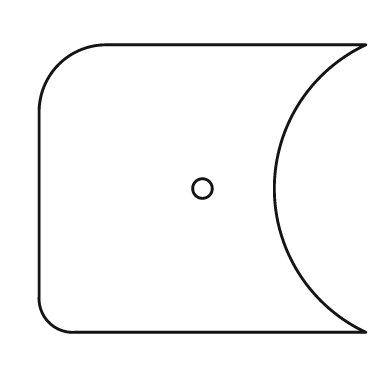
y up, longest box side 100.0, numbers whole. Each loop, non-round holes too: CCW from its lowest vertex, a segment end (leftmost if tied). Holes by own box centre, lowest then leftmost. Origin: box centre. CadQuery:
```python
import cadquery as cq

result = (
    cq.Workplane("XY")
    .moveTo(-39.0, -44.0)
    .lineTo(50.0, -44.0)
    .threePointArc((22.0, 0.0), (50.0, 44.0))
    .lineTo(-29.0, 44.0)
    .threePointArc((-44.0, 38.0), (-50.0, 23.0))
    .lineTo(-50.0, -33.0)
    .threePointArc((-47.0, -41.0), (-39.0, -44.0))
    .close()
    .moveTo(0.0, 0.0)
    .circle(3.0)
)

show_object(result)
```